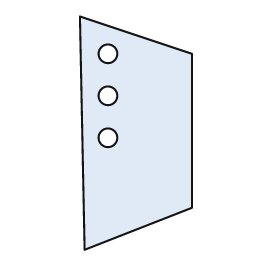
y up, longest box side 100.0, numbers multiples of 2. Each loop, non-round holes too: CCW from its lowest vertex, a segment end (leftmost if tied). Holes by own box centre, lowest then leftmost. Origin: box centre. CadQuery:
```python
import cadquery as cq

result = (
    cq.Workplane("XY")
    .moveTo(-22.0, -50.0)
    .lineTo(24.0, -32.0)
    .lineTo(24.0, 34.0)
    .lineTo(-24.0, 50.0)
    .close()
    .moveTo(-12.0, -2.0)
    .circle(4.0)
    .moveTo(-12.0, 16.0)
    .circle(4.0)
    .moveTo(-12.0, 34.0)
    .circle(4.0)
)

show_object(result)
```